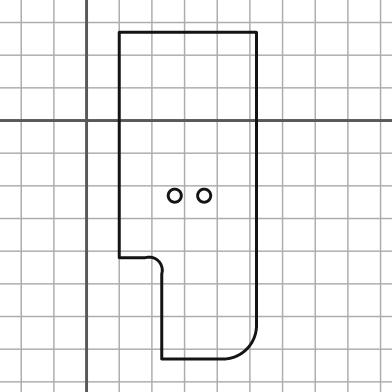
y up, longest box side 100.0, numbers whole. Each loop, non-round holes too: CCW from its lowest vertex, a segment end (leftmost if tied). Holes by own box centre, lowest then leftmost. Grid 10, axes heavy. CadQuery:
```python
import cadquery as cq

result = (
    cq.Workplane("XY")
    .moveTo(23.0, -73.0)
    .lineTo(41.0, -73.0)
    .threePointArc((49.0, -70.0), (52.0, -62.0))
    .lineTo(52.0, 27.0)
    .lineTo(10.0, 27.0)
    .lineTo(10.0, -42.0)
    .lineTo(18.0, -42.0)
    .threePointArc((22.0, -43.0), (23.0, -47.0))
    .close()
    .moveTo(27.0, -23.0)
    .circle(2.0)
    .moveTo(36.0, -23.0)
    .circle(2.0)
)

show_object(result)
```